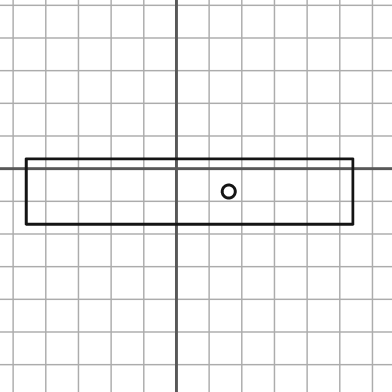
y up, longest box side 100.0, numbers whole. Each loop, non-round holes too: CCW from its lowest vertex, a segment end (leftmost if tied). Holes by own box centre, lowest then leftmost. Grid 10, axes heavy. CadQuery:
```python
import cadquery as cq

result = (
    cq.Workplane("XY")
    .moveTo(-46.0, -17.0)
    .lineTo(54.0, -17.0)
    .lineTo(54.0, 3.0)
    .lineTo(-46.0, 3.0)
    .close()
    .moveTo(16.0, -7.0)
    .circle(2.0)
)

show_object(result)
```